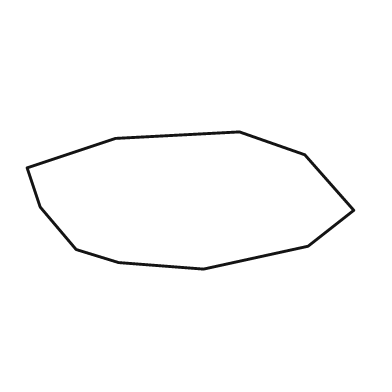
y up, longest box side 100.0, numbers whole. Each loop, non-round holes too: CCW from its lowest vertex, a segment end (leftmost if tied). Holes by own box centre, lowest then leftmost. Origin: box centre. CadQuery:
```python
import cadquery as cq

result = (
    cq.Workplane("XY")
    .moveTo(4.0, -21.0)
    .lineTo(36.0, -14.0)
    .lineTo(50.0, -3.0)
    .lineTo(35.0, 14.0)
    .lineTo(15.0, 21.0)
    .lineTo(-23.0, 19.0)
    .lineTo(-50.0, 10.0)
    .lineTo(-46.0, -2.0)
    .lineTo(-35.0, -15.0)
    .lineTo(-22.0, -19.0)
    .close()
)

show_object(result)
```